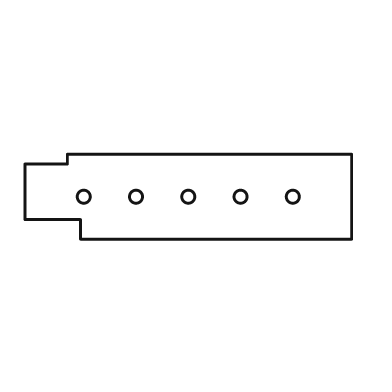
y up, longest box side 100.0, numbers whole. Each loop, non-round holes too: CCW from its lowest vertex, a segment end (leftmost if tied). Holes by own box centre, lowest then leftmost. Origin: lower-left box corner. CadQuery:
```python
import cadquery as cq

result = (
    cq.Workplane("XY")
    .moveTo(17.0, 0.0)
    .lineTo(100.0, 0.0)
    .lineTo(100.0, 26.0)
    .lineTo(13.0, 26.0)
    .lineTo(13.0, 23.0)
    .lineTo(0.0, 23.0)
    .lineTo(0.0, 6.0)
    .lineTo(17.0, 6.0)
    .close()
    .moveTo(18.0, 13.0)
    .circle(2.0)
    .moveTo(34.0, 13.0)
    .circle(2.0)
    .moveTo(50.0, 13.0)
    .circle(2.0)
    .moveTo(66.0, 13.0)
    .circle(2.0)
    .moveTo(82.0, 13.0)
    .circle(2.0)
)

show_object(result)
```